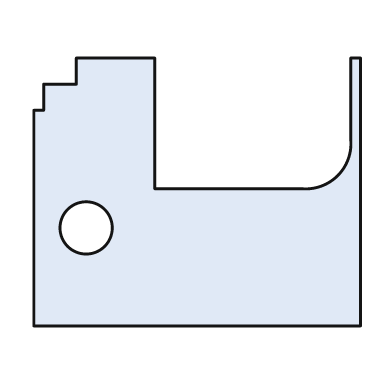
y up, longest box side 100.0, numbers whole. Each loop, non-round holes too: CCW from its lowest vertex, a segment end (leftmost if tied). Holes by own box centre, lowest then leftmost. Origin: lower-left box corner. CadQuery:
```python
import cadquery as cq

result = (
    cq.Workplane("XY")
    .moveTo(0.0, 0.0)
    .lineTo(100.0, 0.0)
    .lineTo(100.0, 82.0)
    .lineTo(97.0, 82.0)
    .lineTo(97.0, 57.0)
    .threePointArc((93.0, 46.0), (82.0, 42.0))
    .lineTo(37.0, 42.0)
    .lineTo(37.0, 82.0)
    .lineTo(13.0, 82.0)
    .lineTo(13.0, 74.0)
    .lineTo(3.0, 74.0)
    .lineTo(3.0, 66.0)
    .lineTo(0.0, 66.0)
    .close()
    .moveTo(16.0, 30.0)
    .circle(8.0)
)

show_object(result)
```